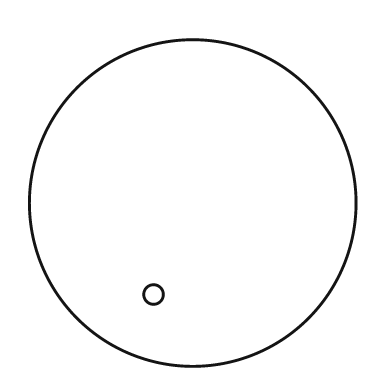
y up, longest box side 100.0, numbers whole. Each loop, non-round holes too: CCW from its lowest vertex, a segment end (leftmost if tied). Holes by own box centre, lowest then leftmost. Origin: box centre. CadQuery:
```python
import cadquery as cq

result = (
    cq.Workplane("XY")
    .moveTo(0.0, 0.0)
    .circle(50.0)
    .moveTo(-12.0, -28.0)
    .circle(3.0)
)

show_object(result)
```